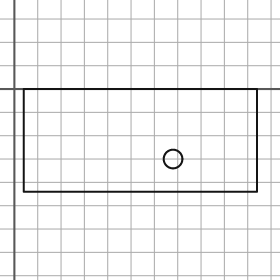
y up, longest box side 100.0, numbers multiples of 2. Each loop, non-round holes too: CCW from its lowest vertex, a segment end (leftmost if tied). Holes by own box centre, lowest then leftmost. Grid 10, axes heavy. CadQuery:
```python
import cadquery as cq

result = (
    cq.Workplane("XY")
    .moveTo(4.0, -44.0)
    .lineTo(104.0, -44.0)
    .lineTo(104.0, 0.0)
    .lineTo(4.0, 0.0)
    .close()
    .moveTo(68.0, -30.0)
    .circle(4.0)
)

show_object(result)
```